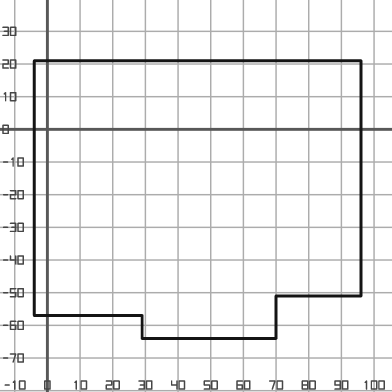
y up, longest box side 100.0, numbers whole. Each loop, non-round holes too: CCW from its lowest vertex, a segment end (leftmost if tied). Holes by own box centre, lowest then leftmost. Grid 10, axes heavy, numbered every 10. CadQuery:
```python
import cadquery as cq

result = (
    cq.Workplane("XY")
    .moveTo(29.0, -64.0)
    .lineTo(70.0, -64.0)
    .lineTo(70.0, -51.0)
    .lineTo(96.0, -51.0)
    .lineTo(96.0, 21.0)
    .lineTo(-4.0, 21.0)
    .lineTo(-4.0, -57.0)
    .lineTo(29.0, -57.0)
    .close()
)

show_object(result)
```